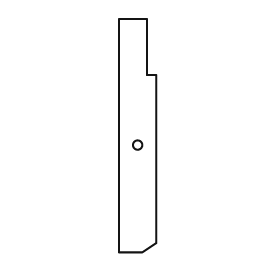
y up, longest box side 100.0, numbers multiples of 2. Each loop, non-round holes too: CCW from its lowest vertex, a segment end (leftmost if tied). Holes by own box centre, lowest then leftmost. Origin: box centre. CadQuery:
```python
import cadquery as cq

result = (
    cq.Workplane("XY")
    .moveTo(-8.0, -50.0)
    .lineTo(2.0, -50.0)
    .lineTo(8.0, -46.0)
    .lineTo(8.0, 26.0)
    .lineTo(4.0, 26.0)
    .lineTo(4.0, 50.0)
    .lineTo(-8.0, 50.0)
    .close()
    .moveTo(0.0, -4.0)
    .circle(2.0)
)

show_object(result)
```